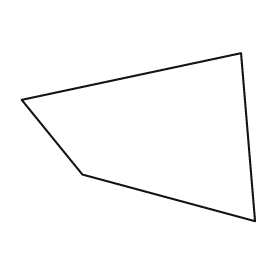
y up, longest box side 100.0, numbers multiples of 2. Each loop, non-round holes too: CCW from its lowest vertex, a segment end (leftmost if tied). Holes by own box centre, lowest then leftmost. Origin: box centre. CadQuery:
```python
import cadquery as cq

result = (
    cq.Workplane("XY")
    .moveTo(50.0, -36.0)
    .lineTo(44.0, 36.0)
    .lineTo(-50.0, 16.0)
    .lineTo(-24.0, -16.0)
    .close()
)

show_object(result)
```